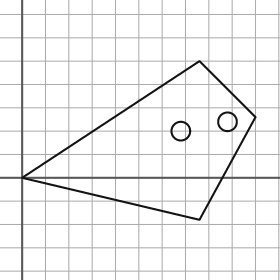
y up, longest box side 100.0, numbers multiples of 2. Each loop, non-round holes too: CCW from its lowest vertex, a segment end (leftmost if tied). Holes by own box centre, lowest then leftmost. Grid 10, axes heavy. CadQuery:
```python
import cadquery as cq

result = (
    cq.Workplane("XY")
    .moveTo(76.0, -18.0)
    .lineTo(100.0, 26.0)
    .lineTo(76.0, 50.0)
    .lineTo(0.0, 0.0)
    .close()
    .moveTo(68.0, 20.0)
    .circle(4.0)
    .moveTo(88.0, 24.0)
    .circle(4.0)
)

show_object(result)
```